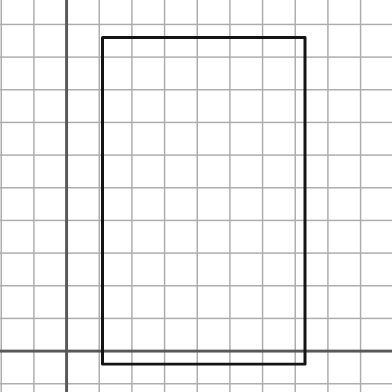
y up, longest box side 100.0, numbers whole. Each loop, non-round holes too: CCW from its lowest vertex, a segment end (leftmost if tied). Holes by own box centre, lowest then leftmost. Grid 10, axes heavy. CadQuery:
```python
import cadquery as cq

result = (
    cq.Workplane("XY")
    .moveTo(11.0, -4.0)
    .lineTo(73.0, -4.0)
    .lineTo(73.0, 96.0)
    .lineTo(11.0, 96.0)
    .close()
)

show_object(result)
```